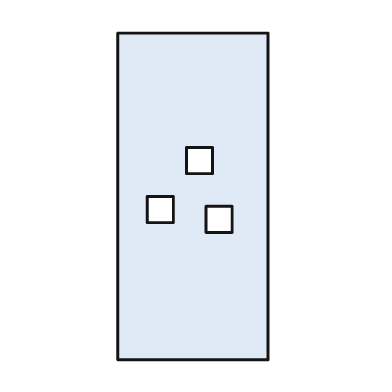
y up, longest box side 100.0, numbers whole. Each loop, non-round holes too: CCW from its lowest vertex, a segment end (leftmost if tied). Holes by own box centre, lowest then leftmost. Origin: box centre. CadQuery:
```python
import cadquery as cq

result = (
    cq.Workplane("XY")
    .moveTo(-23.0, -50.0)
    .lineTo(23.0, -50.0)
    .lineTo(23.0, 50.0)
    .lineTo(-23.0, 50.0)
    .close()
    .moveTo(4.0, -11.0)
    .lineTo(12.0, -11.0)
    .lineTo(12.0, -3.0)
    .lineTo(4.0, -3.0)
    .close()
    .moveTo(-14.0, -8.0)
    .lineTo(-6.0, -8.0)
    .lineTo(-6.0, 0.0)
    .lineTo(-14.0, 0.0)
    .close()
    .moveTo(-2.0, 7.0)
    .lineTo(6.0, 7.0)
    .lineTo(6.0, 15.0)
    .lineTo(-2.0, 15.0)
    .close()
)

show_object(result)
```